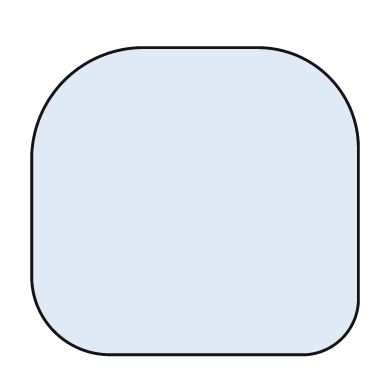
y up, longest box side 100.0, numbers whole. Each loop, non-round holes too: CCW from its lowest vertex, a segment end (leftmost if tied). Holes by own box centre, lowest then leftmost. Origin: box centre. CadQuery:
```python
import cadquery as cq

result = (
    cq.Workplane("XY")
    .moveTo(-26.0, -47.0)
    .lineTo(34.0, -47.0)
    .threePointArc((45.0, -42.0), (50.0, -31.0))
    .lineTo(50.0, 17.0)
    .threePointArc((41.0, 38.0), (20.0, 47.0))
    .lineTo(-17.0, 47.0)
    .threePointArc((-40.0, 37.0), (-50.0, 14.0))
    .lineTo(-50.0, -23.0)
    .threePointArc((-43.0, -40.0), (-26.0, -47.0))
    .close()
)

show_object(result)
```